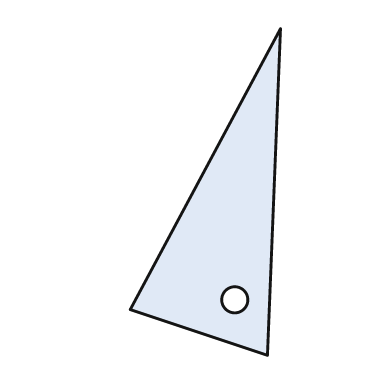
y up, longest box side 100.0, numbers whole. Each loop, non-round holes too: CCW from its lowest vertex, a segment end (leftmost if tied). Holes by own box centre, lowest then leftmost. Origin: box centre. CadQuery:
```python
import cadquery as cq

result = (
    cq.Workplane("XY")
    .moveTo(19.0, -50.0)
    .lineTo(23.0, 50.0)
    .lineTo(-23.0, -36.0)
    .close()
    .moveTo(9.0, -33.0)
    .circle(4.0)
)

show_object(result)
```